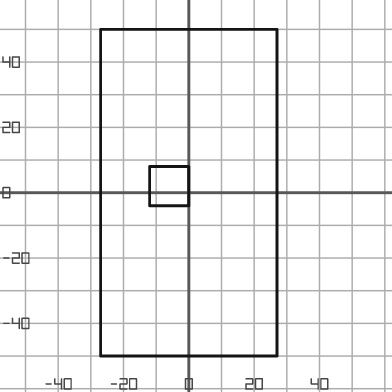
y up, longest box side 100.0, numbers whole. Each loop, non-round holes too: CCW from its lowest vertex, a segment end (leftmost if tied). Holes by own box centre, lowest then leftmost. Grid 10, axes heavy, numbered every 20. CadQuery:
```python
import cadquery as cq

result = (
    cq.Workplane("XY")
    .moveTo(-27.0, -50.0)
    .lineTo(27.0, -50.0)
    .lineTo(27.0, 50.0)
    .lineTo(-27.0, 50.0)
    .close()
    .moveTo(-12.0, -4.0)
    .lineTo(0.0, -4.0)
    .lineTo(0.0, 8.0)
    .lineTo(-12.0, 8.0)
    .close()
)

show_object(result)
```